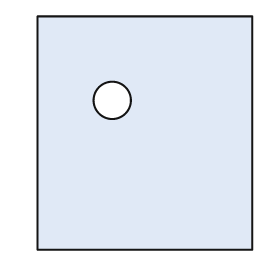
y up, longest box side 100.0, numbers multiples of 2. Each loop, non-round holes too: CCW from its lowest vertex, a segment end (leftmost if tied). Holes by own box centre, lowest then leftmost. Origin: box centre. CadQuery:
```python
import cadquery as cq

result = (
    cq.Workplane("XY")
    .moveTo(-46.0, -50.0)
    .lineTo(46.0, -50.0)
    .lineTo(46.0, 50.0)
    .lineTo(-46.0, 50.0)
    .close()
    .moveTo(-14.0, 14.0)
    .circle(8.0)
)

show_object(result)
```